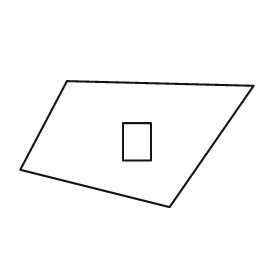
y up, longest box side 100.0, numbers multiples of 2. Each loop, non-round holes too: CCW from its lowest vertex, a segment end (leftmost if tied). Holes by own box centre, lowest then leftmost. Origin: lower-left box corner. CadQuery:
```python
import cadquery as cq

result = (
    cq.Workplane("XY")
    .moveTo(64.0, 0.0)
    .lineTo(100.0, 52.0)
    .lineTo(20.0, 54.0)
    .lineTo(0.0, 16.0)
    .close()
    .moveTo(44.0, 20.0)
    .lineTo(56.0, 20.0)
    .lineTo(56.0, 36.0)
    .lineTo(44.0, 36.0)
    .close()
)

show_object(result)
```